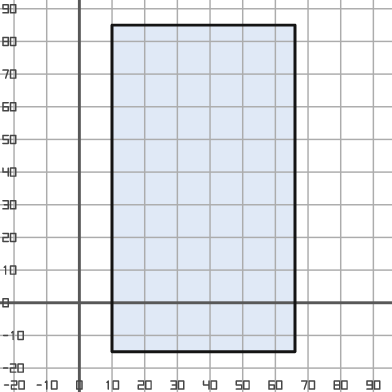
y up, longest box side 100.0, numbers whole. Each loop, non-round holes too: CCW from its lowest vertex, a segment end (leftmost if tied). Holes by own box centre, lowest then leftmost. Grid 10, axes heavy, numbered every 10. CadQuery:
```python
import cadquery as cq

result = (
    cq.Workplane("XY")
    .moveTo(10.0, -15.0)
    .lineTo(66.0, -15.0)
    .lineTo(66.0, 85.0)
    .lineTo(10.0, 85.0)
    .close()
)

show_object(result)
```